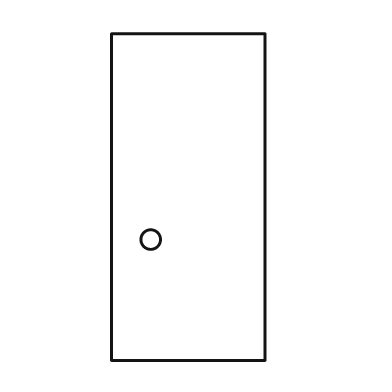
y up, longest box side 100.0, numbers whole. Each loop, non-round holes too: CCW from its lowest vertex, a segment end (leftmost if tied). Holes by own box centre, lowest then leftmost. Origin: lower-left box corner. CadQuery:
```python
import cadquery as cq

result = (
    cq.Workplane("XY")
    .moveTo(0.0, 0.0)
    .lineTo(47.0, 0.0)
    .lineTo(47.0, 100.0)
    .lineTo(0.0, 100.0)
    .close()
    .moveTo(12.0, 37.0)
    .circle(3.0)
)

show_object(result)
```